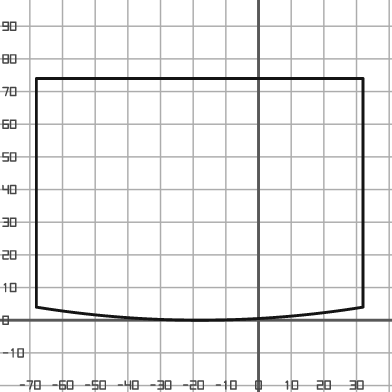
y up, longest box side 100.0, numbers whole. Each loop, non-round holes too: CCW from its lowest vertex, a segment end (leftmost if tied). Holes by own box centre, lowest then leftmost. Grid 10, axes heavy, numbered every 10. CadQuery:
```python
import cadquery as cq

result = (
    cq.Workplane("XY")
    .moveTo(-68.0, 4.0)
    .threePointArc((-18.0, 0.0), (32.0, 4.0))
    .lineTo(32.0, 74.0)
    .lineTo(-68.0, 74.0)
    .close()
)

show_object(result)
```